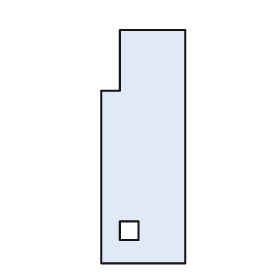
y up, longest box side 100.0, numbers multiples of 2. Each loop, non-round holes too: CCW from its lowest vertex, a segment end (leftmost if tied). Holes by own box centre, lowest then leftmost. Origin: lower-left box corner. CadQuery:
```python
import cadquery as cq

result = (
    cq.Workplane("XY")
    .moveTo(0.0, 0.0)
    .lineTo(36.0, 0.0)
    .lineTo(36.0, 100.0)
    .lineTo(8.0, 100.0)
    .lineTo(8.0, 74.0)
    .lineTo(0.0, 74.0)
    .close()
    .moveTo(8.0, 10.0)
    .lineTo(16.0, 10.0)
    .lineTo(16.0, 18.0)
    .lineTo(8.0, 18.0)
    .close()
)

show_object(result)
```